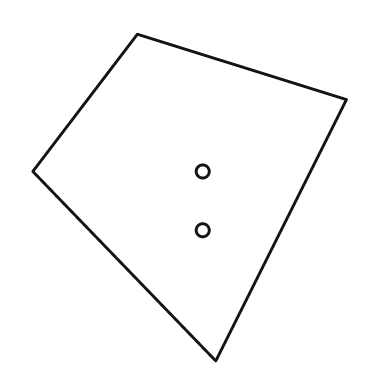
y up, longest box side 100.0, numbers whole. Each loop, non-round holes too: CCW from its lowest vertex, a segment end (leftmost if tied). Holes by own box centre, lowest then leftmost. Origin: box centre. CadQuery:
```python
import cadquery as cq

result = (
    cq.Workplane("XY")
    .moveTo(8.0, -50.0)
    .lineTo(48.0, 30.0)
    .lineTo(-16.0, 50.0)
    .lineTo(-48.0, 8.0)
    .close()
    .moveTo(4.0, -10.0)
    .circle(2.0)
    .moveTo(4.0, 8.0)
    .circle(2.0)
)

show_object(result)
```